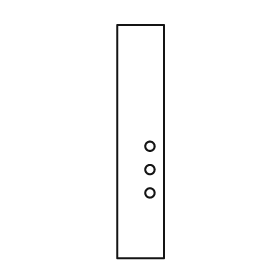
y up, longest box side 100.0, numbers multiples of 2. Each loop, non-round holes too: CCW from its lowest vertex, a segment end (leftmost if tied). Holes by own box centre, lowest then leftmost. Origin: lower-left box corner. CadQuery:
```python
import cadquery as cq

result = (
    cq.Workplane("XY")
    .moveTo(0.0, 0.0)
    .lineTo(20.0, 0.0)
    .lineTo(20.0, 100.0)
    .lineTo(0.0, 100.0)
    .close()
    .moveTo(14.0, 28.0)
    .circle(2.0)
    .moveTo(14.0, 38.0)
    .circle(2.0)
    .moveTo(14.0, 48.0)
    .circle(2.0)
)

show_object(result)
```